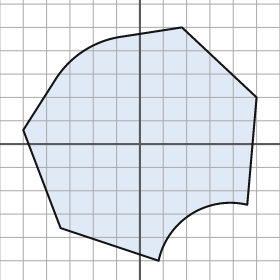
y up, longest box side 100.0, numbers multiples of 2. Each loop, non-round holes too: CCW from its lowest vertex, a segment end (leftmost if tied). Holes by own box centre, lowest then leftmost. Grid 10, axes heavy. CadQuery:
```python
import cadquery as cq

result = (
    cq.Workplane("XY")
    .moveTo(8.0, -50.0)
    .threePointArc((22.0, -30.0), (46.0, -26.0))
    .lineTo(50.0, 20.0)
    .lineTo(18.0, 50.0)
    .lineTo(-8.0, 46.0)
    .threePointArc((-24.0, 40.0), (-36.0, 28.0))
    .lineTo(-50.0, 6.0)
    .lineTo(-34.0, -36.0)
    .close()
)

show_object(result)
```